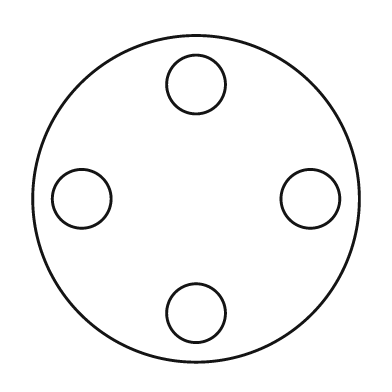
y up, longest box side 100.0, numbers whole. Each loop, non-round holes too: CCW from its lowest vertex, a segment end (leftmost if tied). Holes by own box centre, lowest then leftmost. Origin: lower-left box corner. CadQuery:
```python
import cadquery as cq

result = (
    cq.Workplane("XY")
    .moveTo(50.0, 50.0)
    .circle(50.0)
    .moveTo(50.0, 15.0)
    .circle(9.0)
    .moveTo(15.0, 50.0)
    .circle(9.0)
    .moveTo(85.0, 50.0)
    .circle(9.0)
    .moveTo(50.0, 85.0)
    .circle(9.0)
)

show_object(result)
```